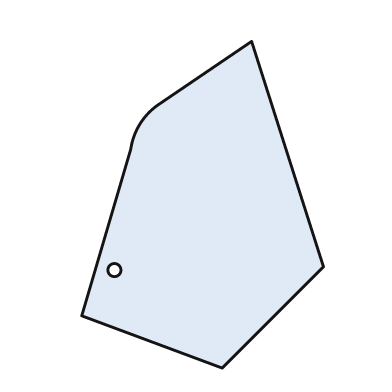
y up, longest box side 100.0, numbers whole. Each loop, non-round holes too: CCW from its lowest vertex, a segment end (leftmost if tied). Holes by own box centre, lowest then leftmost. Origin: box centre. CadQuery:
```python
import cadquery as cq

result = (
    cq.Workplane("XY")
    .moveTo(6.0, -50.0)
    .lineTo(37.0, -19.0)
    .lineTo(15.0, 50.0)
    .lineTo(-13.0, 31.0)
    .threePointArc((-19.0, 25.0), (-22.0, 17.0))
    .lineTo(-37.0, -34.0)
    .close()
    .moveTo(-27.0, -20.0)
    .circle(2.0)
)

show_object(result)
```